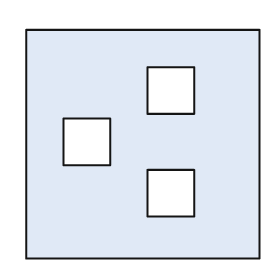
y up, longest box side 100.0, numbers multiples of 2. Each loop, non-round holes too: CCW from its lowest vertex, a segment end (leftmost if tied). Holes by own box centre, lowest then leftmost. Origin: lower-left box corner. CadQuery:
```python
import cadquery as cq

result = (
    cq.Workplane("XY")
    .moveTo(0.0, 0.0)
    .lineTo(100.0, 0.0)
    .lineTo(100.0, 98.0)
    .lineTo(0.0, 98.0)
    .close()
    .moveTo(52.0, 18.0)
    .lineTo(72.0, 18.0)
    .lineTo(72.0, 38.0)
    .lineTo(52.0, 38.0)
    .close()
    .moveTo(16.0, 40.0)
    .lineTo(36.0, 40.0)
    .lineTo(36.0, 60.0)
    .lineTo(16.0, 60.0)
    .close()
    .moveTo(52.0, 62.0)
    .lineTo(72.0, 62.0)
    .lineTo(72.0, 82.0)
    .lineTo(52.0, 82.0)
    .close()
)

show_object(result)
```